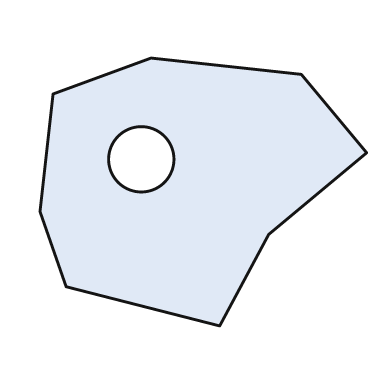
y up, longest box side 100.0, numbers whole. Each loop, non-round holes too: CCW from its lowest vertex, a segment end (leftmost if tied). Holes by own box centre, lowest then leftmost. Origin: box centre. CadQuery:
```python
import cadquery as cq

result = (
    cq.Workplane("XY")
    .moveTo(5.0, -41.0)
    .lineTo(20.0, -13.0)
    .lineTo(50.0, 12.0)
    .lineTo(30.0, 36.0)
    .lineTo(-16.0, 41.0)
    .lineTo(-46.0, 30.0)
    .lineTo(-50.0, -6.0)
    .lineTo(-42.0, -29.0)
    .close()
    .moveTo(-19.0, 10.0)
    .circle(10.0)
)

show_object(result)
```